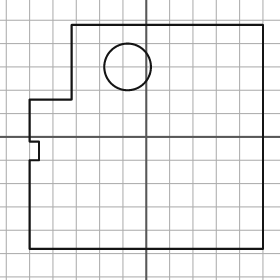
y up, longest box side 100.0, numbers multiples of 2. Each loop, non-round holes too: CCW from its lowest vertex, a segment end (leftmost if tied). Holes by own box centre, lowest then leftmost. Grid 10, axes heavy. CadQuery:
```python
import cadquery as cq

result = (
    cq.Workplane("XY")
    .moveTo(-50.0, -48.0)
    .lineTo(50.0, -48.0)
    .lineTo(50.0, 48.0)
    .lineTo(-32.0, 48.0)
    .lineTo(-32.0, 16.0)
    .lineTo(-50.0, 16.0)
    .lineTo(-50.0, -2.0)
    .lineTo(-46.0, -2.0)
    .lineTo(-46.0, -10.0)
    .lineTo(-50.0, -10.0)
    .close()
    .moveTo(-8.0, 30.0)
    .circle(10.0)
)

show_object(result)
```